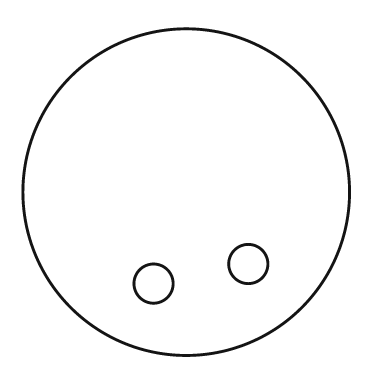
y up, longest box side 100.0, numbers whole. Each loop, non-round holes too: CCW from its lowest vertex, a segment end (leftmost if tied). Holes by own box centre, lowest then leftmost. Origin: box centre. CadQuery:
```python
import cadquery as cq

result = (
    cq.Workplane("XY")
    .moveTo(0.0, 0.0)
    .circle(50.0)
    .moveTo(-10.0, -28.0)
    .circle(6.0)
    .moveTo(19.0, -22.0)
    .circle(6.0)
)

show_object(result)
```